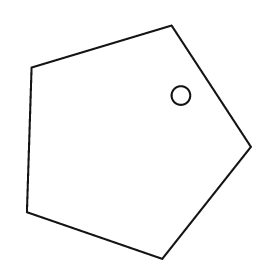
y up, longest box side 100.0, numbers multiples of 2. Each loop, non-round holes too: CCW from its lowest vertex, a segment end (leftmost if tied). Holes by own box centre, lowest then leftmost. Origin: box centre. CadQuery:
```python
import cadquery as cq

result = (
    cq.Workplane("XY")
    .moveTo(10.0, -50.0)
    .lineTo(48.0, -2.0)
    .lineTo(14.0, 50.0)
    .lineTo(-46.0, 32.0)
    .lineTo(-48.0, -30.0)
    .close()
    .moveTo(18.0, 20.0)
    .circle(4.0)
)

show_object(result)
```